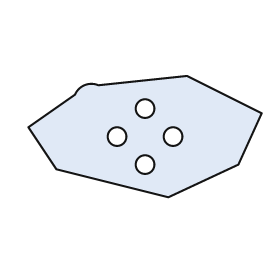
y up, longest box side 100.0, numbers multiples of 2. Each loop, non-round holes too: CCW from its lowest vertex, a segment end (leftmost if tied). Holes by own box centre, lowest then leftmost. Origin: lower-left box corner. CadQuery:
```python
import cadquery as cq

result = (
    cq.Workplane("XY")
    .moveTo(60.0, 0.0)
    .lineTo(90.0, 14.0)
    .lineTo(100.0, 36.0)
    .lineTo(68.0, 52.0)
    .lineTo(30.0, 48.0)
    .threePointArc((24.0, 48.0), (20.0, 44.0))
    .lineTo(0.0, 30.0)
    .lineTo(12.0, 12.0)
    .close()
    .moveTo(50.0, 14.0)
    .circle(4.0)
    .moveTo(38.0, 26.0)
    .circle(4.0)
    .moveTo(62.0, 26.0)
    .circle(4.0)
    .moveTo(50.0, 38.0)
    .circle(4.0)
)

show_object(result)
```